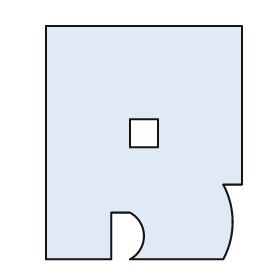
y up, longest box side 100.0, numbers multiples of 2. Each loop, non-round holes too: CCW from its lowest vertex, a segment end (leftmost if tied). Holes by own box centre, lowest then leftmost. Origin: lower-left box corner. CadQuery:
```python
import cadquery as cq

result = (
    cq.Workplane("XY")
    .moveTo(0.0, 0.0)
    .lineTo(28.0, 0.0)
    .lineTo(28.0, 20.0)
    .lineTo(36.0, 20.0)
    .threePointArc((42.0, 10.0), (36.0, 0.0))
    .lineTo(76.0, 0.0)
    .threePointArc((80.0, 16.0), (76.0, 32.0))
    .lineTo(84.0, 32.0)
    .lineTo(84.0, 100.0)
    .lineTo(0.0, 100.0)
    .close()
    .moveTo(36.0, 48.0)
    .lineTo(48.0, 48.0)
    .lineTo(48.0, 60.0)
    .lineTo(36.0, 60.0)
    .close()
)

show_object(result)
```